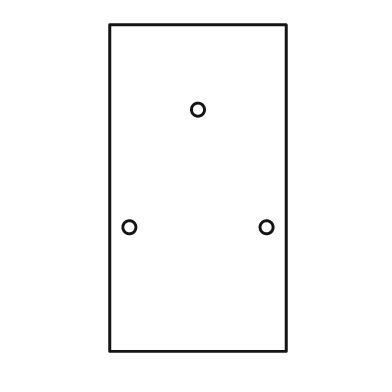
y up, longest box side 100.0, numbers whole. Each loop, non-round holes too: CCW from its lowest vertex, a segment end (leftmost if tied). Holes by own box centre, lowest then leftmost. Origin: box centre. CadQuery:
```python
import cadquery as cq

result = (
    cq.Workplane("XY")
    .moveTo(-27.0, -50.0)
    .lineTo(27.0, -50.0)
    .lineTo(27.0, 50.0)
    .lineTo(-27.0, 50.0)
    .close()
    .moveTo(-21.0, -12.0)
    .circle(2.0)
    .moveTo(21.0, -12.0)
    .circle(2.0)
    .moveTo(0.0, 24.0)
    .circle(2.0)
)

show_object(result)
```